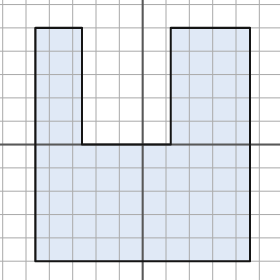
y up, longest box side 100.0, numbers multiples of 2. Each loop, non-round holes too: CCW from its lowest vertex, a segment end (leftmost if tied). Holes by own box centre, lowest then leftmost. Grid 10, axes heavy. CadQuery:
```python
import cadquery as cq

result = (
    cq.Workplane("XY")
    .moveTo(-46.0, -50.0)
    .lineTo(46.0, -50.0)
    .lineTo(46.0, 50.0)
    .lineTo(12.0, 50.0)
    .lineTo(12.0, 0.0)
    .lineTo(-26.0, 0.0)
    .lineTo(-26.0, 50.0)
    .lineTo(-46.0, 50.0)
    .close()
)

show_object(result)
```